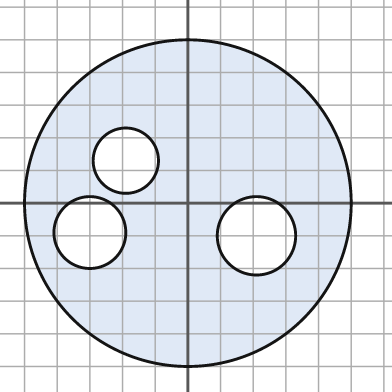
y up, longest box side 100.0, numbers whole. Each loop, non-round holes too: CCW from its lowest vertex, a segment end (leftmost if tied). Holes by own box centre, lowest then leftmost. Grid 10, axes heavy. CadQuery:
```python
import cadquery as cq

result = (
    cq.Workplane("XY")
    .moveTo(0.0, 0.0)
    .circle(50.0)
    .moveTo(21.0, -10.0)
    .circle(12.0)
    .moveTo(-30.0, -9.0)
    .circle(11.0)
    .moveTo(-19.0, 13.0)
    .circle(10.0)
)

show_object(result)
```